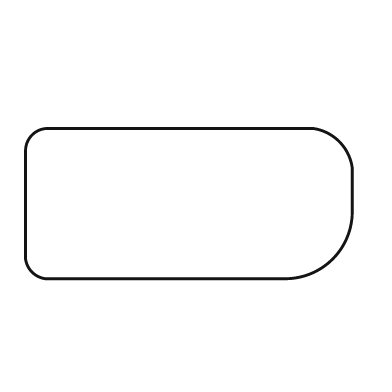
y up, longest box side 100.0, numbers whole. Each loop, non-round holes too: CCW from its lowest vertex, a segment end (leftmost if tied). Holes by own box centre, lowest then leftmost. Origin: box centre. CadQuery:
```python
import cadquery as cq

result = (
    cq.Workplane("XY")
    .moveTo(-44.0, -23.0)
    .lineTo(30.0, -23.0)
    .threePointArc((44.0, -17.0), (50.0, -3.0))
    .lineTo(50.0, 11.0)
    .threePointArc((46.0, 19.0), (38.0, 23.0))
    .lineTo(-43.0, 23.0)
    .threePointArc((-48.0, 21.0), (-50.0, 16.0))
    .lineTo(-50.0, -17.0)
    .threePointArc((-48.0, -21.0), (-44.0, -23.0))
    .close()
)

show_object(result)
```